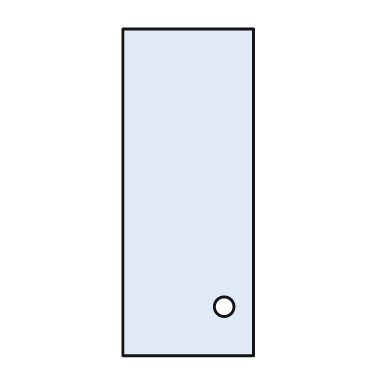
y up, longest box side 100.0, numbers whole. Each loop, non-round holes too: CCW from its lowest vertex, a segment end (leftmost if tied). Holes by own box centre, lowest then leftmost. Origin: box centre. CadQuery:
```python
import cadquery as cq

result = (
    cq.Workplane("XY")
    .moveTo(-20.0, -50.0)
    .lineTo(20.0, -50.0)
    .lineTo(20.0, 50.0)
    .lineTo(-20.0, 50.0)
    .close()
    .moveTo(11.0, -35.0)
    .circle(3.0)
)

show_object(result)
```